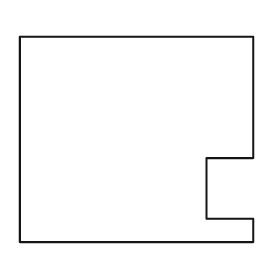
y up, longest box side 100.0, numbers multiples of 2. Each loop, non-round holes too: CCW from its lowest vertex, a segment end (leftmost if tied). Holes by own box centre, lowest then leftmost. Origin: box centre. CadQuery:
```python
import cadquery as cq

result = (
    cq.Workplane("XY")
    .moveTo(-50.0, -44.0)
    .lineTo(50.0, -44.0)
    .lineTo(50.0, -34.0)
    .lineTo(30.0, -34.0)
    .lineTo(30.0, -8.0)
    .lineTo(50.0, -8.0)
    .lineTo(50.0, 44.0)
    .lineTo(-50.0, 44.0)
    .close()
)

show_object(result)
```